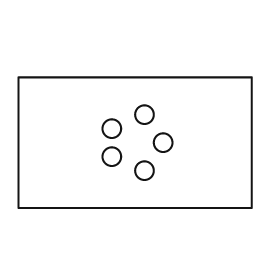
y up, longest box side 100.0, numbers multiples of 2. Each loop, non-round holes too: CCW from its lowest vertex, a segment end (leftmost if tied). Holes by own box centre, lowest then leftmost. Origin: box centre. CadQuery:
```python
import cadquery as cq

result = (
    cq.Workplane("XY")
    .moveTo(-50.0, -28.0)
    .lineTo(50.0, -28.0)
    .lineTo(50.0, 28.0)
    .lineTo(-50.0, 28.0)
    .close()
    .moveTo(4.0, -12.0)
    .circle(4.0)
    .moveTo(-10.0, -6.0)
    .circle(4.0)
    .moveTo(12.0, 0.0)
    .circle(4.0)
    .moveTo(-10.0, 6.0)
    .circle(4.0)
    .moveTo(4.0, 12.0)
    .circle(4.0)
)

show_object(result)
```